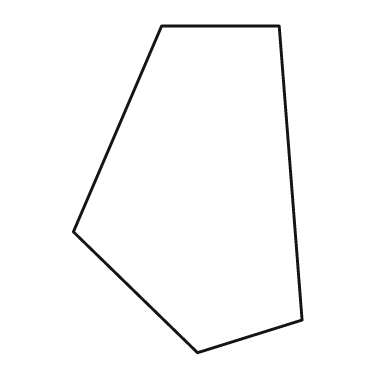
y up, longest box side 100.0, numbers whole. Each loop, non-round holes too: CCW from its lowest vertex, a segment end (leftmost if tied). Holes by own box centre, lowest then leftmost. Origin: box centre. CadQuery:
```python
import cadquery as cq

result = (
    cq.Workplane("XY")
    .moveTo(3.0, -50.0)
    .lineTo(35.0, -40.0)
    .lineTo(28.0, 50.0)
    .lineTo(-8.0, 50.0)
    .lineTo(-35.0, -13.0)
    .close()
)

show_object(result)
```